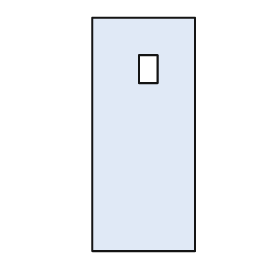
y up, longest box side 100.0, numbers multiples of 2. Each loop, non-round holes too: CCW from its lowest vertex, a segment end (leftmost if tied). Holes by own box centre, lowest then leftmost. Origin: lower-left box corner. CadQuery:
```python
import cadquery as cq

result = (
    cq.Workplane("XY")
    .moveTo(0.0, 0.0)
    .lineTo(44.0, 0.0)
    .lineTo(44.0, 100.0)
    .lineTo(0.0, 100.0)
    .close()
    .moveTo(20.0, 72.0)
    .lineTo(28.0, 72.0)
    .lineTo(28.0, 84.0)
    .lineTo(20.0, 84.0)
    .close()
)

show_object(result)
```